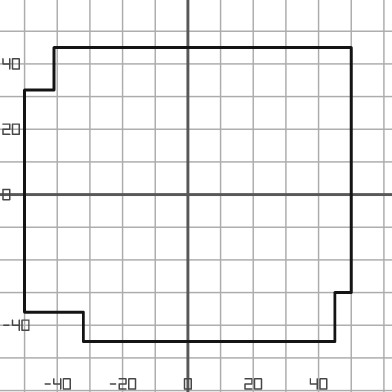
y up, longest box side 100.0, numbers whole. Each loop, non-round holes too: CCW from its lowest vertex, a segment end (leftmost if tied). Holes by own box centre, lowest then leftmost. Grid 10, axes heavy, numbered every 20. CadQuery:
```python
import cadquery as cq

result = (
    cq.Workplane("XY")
    .moveTo(-32.0, -45.0)
    .lineTo(45.0, -45.0)
    .lineTo(45.0, -30.0)
    .lineTo(50.0, -30.0)
    .lineTo(50.0, 45.0)
    .lineTo(-41.0, 45.0)
    .lineTo(-41.0, 32.0)
    .lineTo(-50.0, 32.0)
    .lineTo(-50.0, -36.0)
    .lineTo(-32.0, -36.0)
    .close()
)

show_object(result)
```